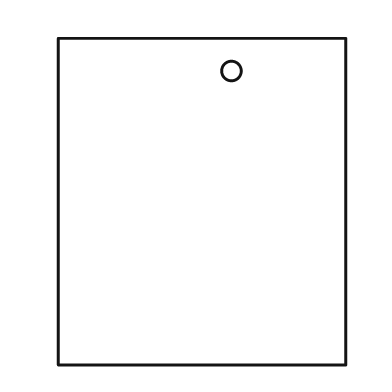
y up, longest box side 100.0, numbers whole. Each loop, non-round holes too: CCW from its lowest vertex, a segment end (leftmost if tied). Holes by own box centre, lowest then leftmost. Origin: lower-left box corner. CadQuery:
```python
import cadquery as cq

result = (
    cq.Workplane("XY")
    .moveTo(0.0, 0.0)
    .lineTo(88.0, 0.0)
    .lineTo(88.0, 100.0)
    .lineTo(0.0, 100.0)
    .close()
    .moveTo(53.0, 90.0)
    .circle(3.0)
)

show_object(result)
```